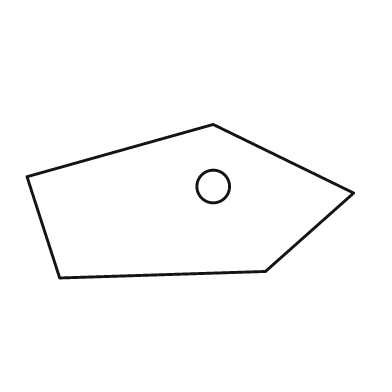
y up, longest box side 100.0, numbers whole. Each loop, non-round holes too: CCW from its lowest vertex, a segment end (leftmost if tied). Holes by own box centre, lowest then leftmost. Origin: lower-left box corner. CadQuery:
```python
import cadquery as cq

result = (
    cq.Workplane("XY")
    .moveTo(10.0, 0.0)
    .lineTo(73.0, 2.0)
    .lineTo(100.0, 26.0)
    .lineTo(57.0, 47.0)
    .lineTo(0.0, 31.0)
    .close()
    .moveTo(57.0, 28.0)
    .circle(5.0)
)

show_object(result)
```